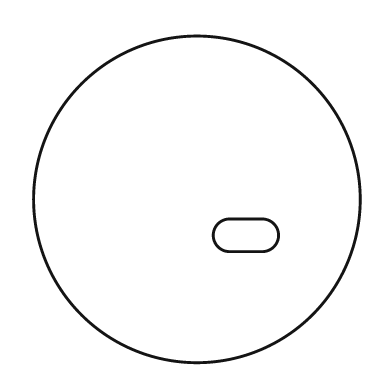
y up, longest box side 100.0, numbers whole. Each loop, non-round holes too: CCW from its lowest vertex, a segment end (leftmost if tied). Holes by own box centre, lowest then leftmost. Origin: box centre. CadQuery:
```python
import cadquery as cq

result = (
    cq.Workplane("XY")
    .moveTo(0.0, 0.0)
    .circle(50.0)
    .moveTo(10.0, -16.0)
    .lineTo(20.0, -16.0)
    .threePointArc((25.0, -11.0), (20.0, -6.0))
    .lineTo(10.0, -6.0)
    .threePointArc((5.0, -11.0), (10.0, -16.0))
    .close()
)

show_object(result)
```